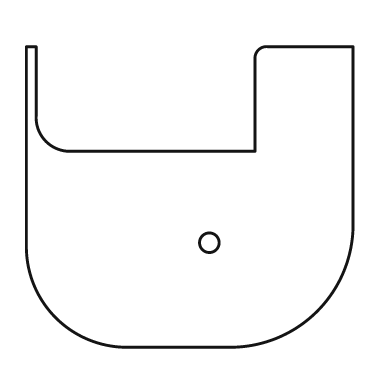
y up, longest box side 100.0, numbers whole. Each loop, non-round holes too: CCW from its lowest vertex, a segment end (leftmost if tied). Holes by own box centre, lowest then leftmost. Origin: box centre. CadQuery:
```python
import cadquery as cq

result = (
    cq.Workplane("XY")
    .moveTo(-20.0, -46.0)
    .lineTo(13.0, -46.0)
    .threePointArc((39.0, -35.0), (50.0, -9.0))
    .lineTo(50.0, 46.0)
    .lineTo(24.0, 46.0)
    .threePointArc((21.0, 45.0), (20.0, 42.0))
    .lineTo(20.0, 14.0)
    .lineTo(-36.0, 14.0)
    .threePointArc((-44.0, 17.0), (-47.0, 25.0))
    .lineTo(-47.0, 46.0)
    .lineTo(-50.0, 46.0)
    .lineTo(-50.0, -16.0)
    .threePointArc((-41.0, -37.0), (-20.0, -46.0))
    .close()
    .moveTo(6.0, -14.0)
    .circle(3.0)
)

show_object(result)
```